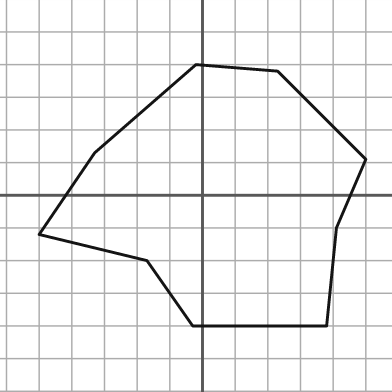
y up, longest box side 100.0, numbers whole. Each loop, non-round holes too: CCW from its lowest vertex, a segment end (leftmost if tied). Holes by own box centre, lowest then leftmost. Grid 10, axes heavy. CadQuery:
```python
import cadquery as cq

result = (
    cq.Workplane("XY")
    .moveTo(-3.0, -40.0)
    .lineTo(38.0, -40.0)
    .lineTo(41.0, -10.0)
    .lineTo(50.0, 11.0)
    .lineTo(23.0, 38.0)
    .lineTo(-2.0, 40.0)
    .lineTo(-33.0, 13.0)
    .lineTo(-50.0, -12.0)
    .lineTo(-17.0, -20.0)
    .close()
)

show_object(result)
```